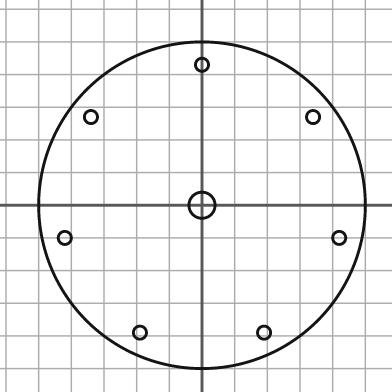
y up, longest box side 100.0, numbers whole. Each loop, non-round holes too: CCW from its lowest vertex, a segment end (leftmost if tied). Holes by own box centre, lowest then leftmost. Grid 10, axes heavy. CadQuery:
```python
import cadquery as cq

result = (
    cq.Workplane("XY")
    .moveTo(0.0, 0.0)
    .circle(50.0)
    .moveTo(-19.0, -39.0)
    .circle(2.0)
    .moveTo(19.0, -39.0)
    .circle(2.0)
    .moveTo(-42.0, -10.0)
    .circle(2.0)
    .moveTo(42.0, -10.0)
    .circle(2.0)
    .moveTo(0.0, 0.0)
    .circle(4.0)
    .moveTo(-34.0, 27.0)
    .circle(2.0)
    .moveTo(34.0, 27.0)
    .circle(2.0)
    .moveTo(0.0, 43.0)
    .circle(2.0)
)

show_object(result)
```